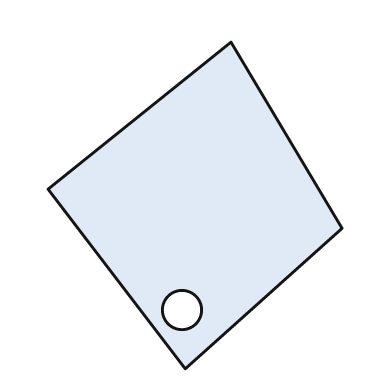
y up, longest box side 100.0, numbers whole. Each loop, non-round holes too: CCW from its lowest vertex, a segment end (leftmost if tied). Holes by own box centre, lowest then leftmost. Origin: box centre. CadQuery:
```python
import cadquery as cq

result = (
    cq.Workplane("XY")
    .moveTo(-3.0, -50.0)
    .lineTo(45.0, -7.0)
    .lineTo(11.0, 50.0)
    .lineTo(-45.0, 5.0)
    .close()
    .moveTo(-4.0, -32.0)
    .circle(6.0)
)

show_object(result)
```